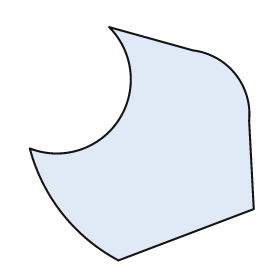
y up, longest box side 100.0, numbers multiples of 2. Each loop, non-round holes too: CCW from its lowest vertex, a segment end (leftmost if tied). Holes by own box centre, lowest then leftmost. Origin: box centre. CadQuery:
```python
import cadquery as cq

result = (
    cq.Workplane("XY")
    .moveTo(-10.0, -50.0)
    .lineTo(48.0, -28.0)
    .lineTo(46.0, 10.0)
    .threePointArc((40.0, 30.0), (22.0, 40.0))
    .lineTo(-14.0, 50.0)
    .threePointArc((-10.0, 10.0), (-48.0, -2.0))
    .threePointArc((-34.0, -30.0), (-10.0, -50.0))
    .close()
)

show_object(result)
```